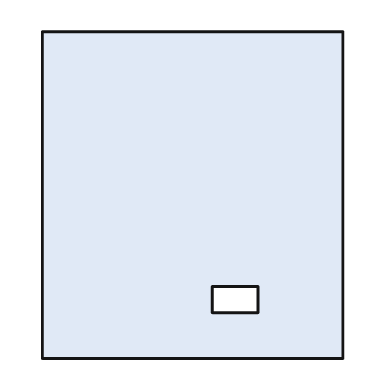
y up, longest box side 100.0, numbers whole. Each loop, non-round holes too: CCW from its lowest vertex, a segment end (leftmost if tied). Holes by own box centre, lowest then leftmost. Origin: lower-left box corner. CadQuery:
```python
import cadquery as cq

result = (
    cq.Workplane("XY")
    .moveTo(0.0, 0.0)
    .lineTo(92.0, 0.0)
    .lineTo(92.0, 100.0)
    .lineTo(0.0, 100.0)
    .close()
    .moveTo(52.0, 14.0)
    .lineTo(66.0, 14.0)
    .lineTo(66.0, 22.0)
    .lineTo(52.0, 22.0)
    .close()
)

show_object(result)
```